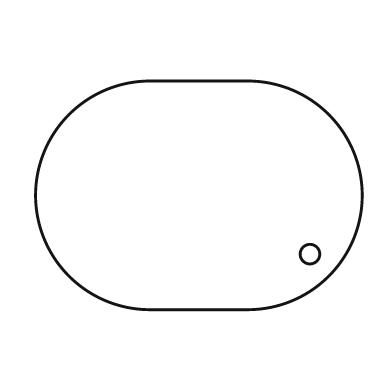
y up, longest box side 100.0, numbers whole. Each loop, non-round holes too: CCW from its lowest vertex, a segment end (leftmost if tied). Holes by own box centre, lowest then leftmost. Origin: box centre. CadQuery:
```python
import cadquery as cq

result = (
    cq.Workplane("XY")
    .moveTo(-15.0, -35.0)
    .lineTo(15.0, -35.0)
    .threePointArc((50.0, 0.0), (15.0, 35.0))
    .lineTo(-15.0, 35.0)
    .threePointArc((-50.0, 0.0), (-15.0, -35.0))
    .close()
    .moveTo(34.0, -18.0)
    .circle(3.0)
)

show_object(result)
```